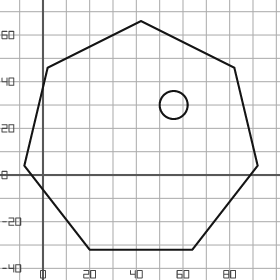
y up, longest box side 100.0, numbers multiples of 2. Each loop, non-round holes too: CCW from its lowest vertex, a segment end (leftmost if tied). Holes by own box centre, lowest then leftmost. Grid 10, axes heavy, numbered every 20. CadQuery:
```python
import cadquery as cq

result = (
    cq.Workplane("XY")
    .moveTo(20.0, -32.0)
    .lineTo(64.0, -32.0)
    .lineTo(92.0, 4.0)
    .lineTo(82.0, 46.0)
    .lineTo(42.0, 66.0)
    .lineTo(2.0, 46.0)
    .lineTo(-8.0, 4.0)
    .close()
    .moveTo(56.0, 30.0)
    .circle(6.0)
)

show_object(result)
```